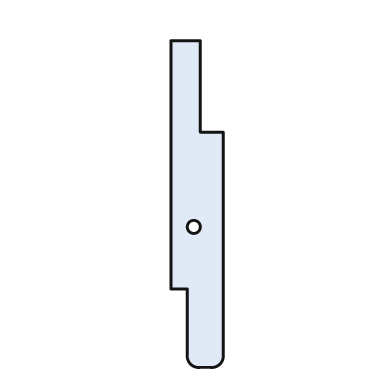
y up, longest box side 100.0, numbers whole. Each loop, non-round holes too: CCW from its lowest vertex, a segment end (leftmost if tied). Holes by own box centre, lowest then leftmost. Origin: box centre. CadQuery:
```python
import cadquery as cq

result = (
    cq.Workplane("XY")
    .moveTo(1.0, -50.0)
    .lineTo(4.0, -50.0)
    .threePointArc((7.0, -49.0), (8.0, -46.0))
    .lineTo(8.0, 22.0)
    .lineTo(1.0, 22.0)
    .lineTo(1.0, 50.0)
    .lineTo(-8.0, 50.0)
    .lineTo(-8.0, -26.0)
    .lineTo(-3.0, -26.0)
    .lineTo(-3.0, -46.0)
    .threePointArc((-2.0, -49.0), (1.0, -50.0))
    .close()
    .moveTo(-1.0, -7.0)
    .circle(2.0)
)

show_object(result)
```